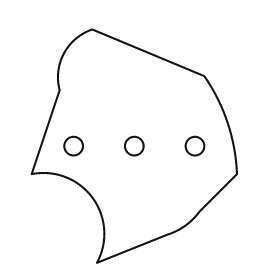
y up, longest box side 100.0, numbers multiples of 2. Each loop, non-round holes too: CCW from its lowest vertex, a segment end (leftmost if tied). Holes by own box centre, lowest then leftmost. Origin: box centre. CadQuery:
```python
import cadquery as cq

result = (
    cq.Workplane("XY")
    .moveTo(-16.0, -50.0)
    .lineTo(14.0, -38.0)
    .threePointArc((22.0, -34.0), (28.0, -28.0))
    .lineTo(44.0, -12.0)
    .threePointArc((40.0, 10.0), (30.0, 30.0))
    .lineTo(-18.0, 50.0)
    .threePointArc((-30.0, 40.0), (-32.0, 24.0))
    .lineTo(-44.0, -12.0)
    .threePointArc((-18.0, -22.0), (-16.0, -50.0))
    .close()
    .moveTo(-26.0, 0.0)
    .circle(4.0)
    .moveTo(0.0, 0.0)
    .circle(4.0)
    .moveTo(26.0, 0.0)
    .circle(4.0)
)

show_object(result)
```